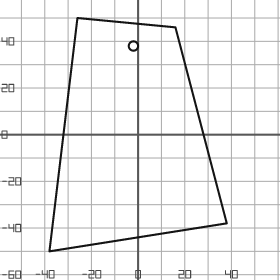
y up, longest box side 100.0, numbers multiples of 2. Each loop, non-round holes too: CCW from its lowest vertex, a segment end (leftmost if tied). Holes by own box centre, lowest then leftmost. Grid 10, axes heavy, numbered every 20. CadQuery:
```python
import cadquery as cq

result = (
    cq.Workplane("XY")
    .moveTo(-38.0, -50.0)
    .lineTo(38.0, -38.0)
    .lineTo(16.0, 46.0)
    .lineTo(-26.0, 50.0)
    .close()
    .moveTo(-2.0, 38.0)
    .circle(2.0)
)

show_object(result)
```